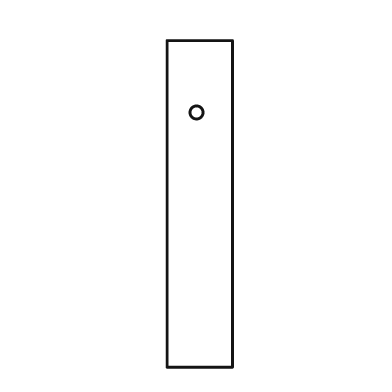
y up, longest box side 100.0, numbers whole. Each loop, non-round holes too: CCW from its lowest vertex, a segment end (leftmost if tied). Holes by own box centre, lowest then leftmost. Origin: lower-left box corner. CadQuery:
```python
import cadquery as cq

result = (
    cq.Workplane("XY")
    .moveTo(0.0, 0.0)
    .lineTo(20.0, 0.0)
    .lineTo(20.0, 100.0)
    .lineTo(0.0, 100.0)
    .close()
    .moveTo(9.0, 78.0)
    .circle(2.0)
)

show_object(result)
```